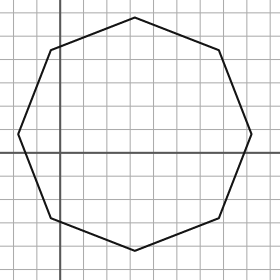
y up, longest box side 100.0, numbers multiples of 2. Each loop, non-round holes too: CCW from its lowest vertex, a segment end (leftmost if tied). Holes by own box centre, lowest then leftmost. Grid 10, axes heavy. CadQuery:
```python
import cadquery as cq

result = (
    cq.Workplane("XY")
    .moveTo(32.0, -42.0)
    .lineTo(68.0, -28.0)
    .lineTo(82.0, 8.0)
    .lineTo(68.0, 44.0)
    .lineTo(32.0, 58.0)
    .lineTo(-4.0, 44.0)
    .lineTo(-18.0, 8.0)
    .lineTo(-4.0, -28.0)
    .close()
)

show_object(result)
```